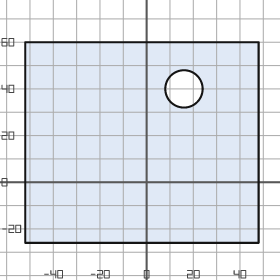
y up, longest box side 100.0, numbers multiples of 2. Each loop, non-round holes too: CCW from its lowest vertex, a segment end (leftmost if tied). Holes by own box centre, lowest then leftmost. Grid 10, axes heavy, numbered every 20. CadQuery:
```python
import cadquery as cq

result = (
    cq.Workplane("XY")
    .moveTo(-52.0, -26.0)
    .lineTo(48.0, -26.0)
    .lineTo(48.0, 60.0)
    .lineTo(-52.0, 60.0)
    .close()
    .moveTo(16.0, 40.0)
    .circle(8.0)
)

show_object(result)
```